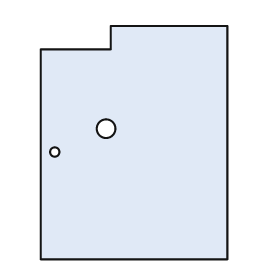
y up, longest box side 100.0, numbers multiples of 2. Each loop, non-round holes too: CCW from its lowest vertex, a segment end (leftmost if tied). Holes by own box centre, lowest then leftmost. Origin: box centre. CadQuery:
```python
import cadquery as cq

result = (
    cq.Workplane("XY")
    .moveTo(-40.0, -50.0)
    .lineTo(40.0, -50.0)
    .lineTo(40.0, 50.0)
    .lineTo(-10.0, 50.0)
    .lineTo(-10.0, 40.0)
    .lineTo(-40.0, 40.0)
    .close()
    .moveTo(-34.0, -4.0)
    .circle(2.0)
    .moveTo(-12.0, 6.0)
    .circle(4.0)
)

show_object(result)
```